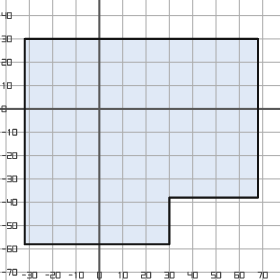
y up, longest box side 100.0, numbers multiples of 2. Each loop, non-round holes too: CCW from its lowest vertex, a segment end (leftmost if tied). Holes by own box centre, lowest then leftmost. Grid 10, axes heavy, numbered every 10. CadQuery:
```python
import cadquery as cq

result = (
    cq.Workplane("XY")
    .moveTo(-32.0, -58.0)
    .lineTo(30.0, -58.0)
    .lineTo(30.0, -38.0)
    .lineTo(68.0, -38.0)
    .lineTo(68.0, 30.0)
    .lineTo(-32.0, 30.0)
    .close()
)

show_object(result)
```